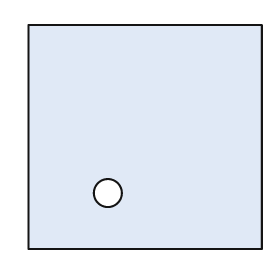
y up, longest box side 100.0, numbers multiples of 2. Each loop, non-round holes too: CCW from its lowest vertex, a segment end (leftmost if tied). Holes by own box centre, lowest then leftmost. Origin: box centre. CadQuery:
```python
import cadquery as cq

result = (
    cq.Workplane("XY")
    .moveTo(-50.0, -48.0)
    .lineTo(50.0, -48.0)
    .lineTo(50.0, 48.0)
    .lineTo(-50.0, 48.0)
    .close()
    .moveTo(-16.0, -24.0)
    .circle(6.0)
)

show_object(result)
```